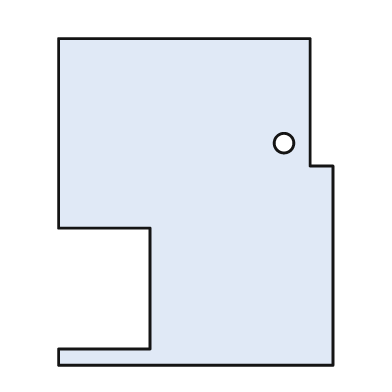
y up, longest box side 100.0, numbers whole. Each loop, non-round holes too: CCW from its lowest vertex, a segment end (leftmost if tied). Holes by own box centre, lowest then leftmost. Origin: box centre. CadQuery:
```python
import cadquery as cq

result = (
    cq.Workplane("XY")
    .moveTo(-42.0, -50.0)
    .lineTo(42.0, -50.0)
    .lineTo(42.0, 11.0)
    .lineTo(35.0, 11.0)
    .lineTo(35.0, 50.0)
    .lineTo(-42.0, 50.0)
    .lineTo(-42.0, -8.0)
    .lineTo(-14.0, -8.0)
    .lineTo(-14.0, -45.0)
    .lineTo(-42.0, -45.0)
    .close()
    .moveTo(27.0, 18.0)
    .circle(3.0)
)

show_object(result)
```